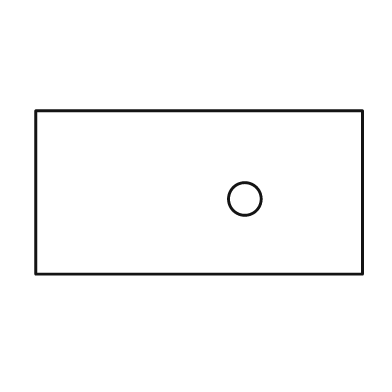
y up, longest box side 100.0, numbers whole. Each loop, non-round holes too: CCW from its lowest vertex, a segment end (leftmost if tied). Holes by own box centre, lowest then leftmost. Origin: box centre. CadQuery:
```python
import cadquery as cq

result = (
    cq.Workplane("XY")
    .moveTo(-50.0, -25.0)
    .lineTo(50.0, -25.0)
    .lineTo(50.0, 25.0)
    .lineTo(-50.0, 25.0)
    .close()
    .moveTo(14.0, -2.0)
    .circle(5.0)
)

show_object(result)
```